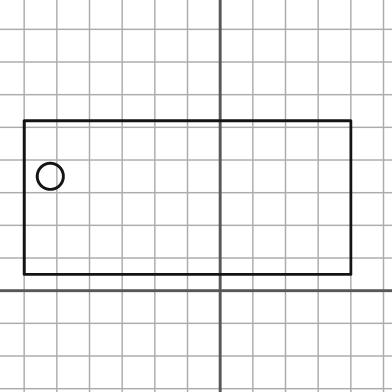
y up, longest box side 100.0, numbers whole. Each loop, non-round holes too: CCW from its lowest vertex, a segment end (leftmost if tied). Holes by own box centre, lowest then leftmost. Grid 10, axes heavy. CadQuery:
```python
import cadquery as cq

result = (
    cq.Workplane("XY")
    .moveTo(-60.0, 5.0)
    .lineTo(40.0, 5.0)
    .lineTo(40.0, 52.0)
    .lineTo(-60.0, 52.0)
    .close()
    .moveTo(-52.0, 35.0)
    .circle(4.0)
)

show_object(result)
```